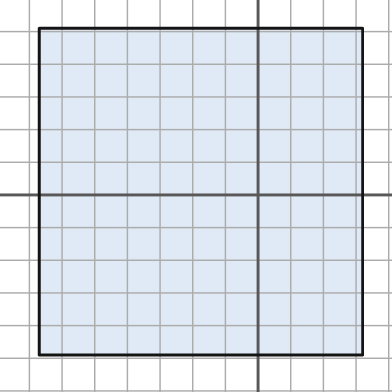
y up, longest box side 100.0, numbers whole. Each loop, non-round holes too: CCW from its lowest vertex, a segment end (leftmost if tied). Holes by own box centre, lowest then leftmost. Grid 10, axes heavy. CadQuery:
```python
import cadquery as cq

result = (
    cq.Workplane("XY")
    .moveTo(-67.0, -49.0)
    .lineTo(32.0, -49.0)
    .lineTo(32.0, 51.0)
    .lineTo(-67.0, 51.0)
    .close()
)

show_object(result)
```